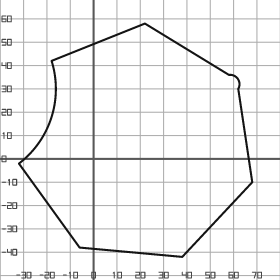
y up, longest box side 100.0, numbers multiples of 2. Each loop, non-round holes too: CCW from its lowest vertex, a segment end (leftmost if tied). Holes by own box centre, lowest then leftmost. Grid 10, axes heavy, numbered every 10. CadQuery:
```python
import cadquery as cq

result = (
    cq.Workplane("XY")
    .moveTo(38.0, -42.0)
    .lineTo(68.0, -10.0)
    .lineTo(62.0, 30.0)
    .threePointArc((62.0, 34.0), (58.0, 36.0))
    .lineTo(22.0, 58.0)
    .lineTo(-18.0, 42.0)
    .threePointArc((-18.0, 18.0), (-32.0, -2.0))
    .lineTo(-6.0, -38.0)
    .close()
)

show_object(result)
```